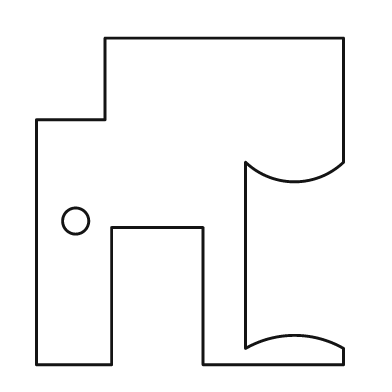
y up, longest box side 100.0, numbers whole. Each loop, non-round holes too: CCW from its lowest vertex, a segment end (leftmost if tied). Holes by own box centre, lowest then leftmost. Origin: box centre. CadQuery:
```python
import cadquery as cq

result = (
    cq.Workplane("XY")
    .moveTo(-47.0, -50.0)
    .lineTo(-24.0, -50.0)
    .lineTo(-24.0, -8.0)
    .lineTo(4.0, -8.0)
    .lineTo(4.0, -50.0)
    .lineTo(47.0, -50.0)
    .lineTo(47.0, -45.0)
    .threePointArc((32.0, -41.0), (17.0, -45.0))
    .lineTo(17.0, 12.0)
    .threePointArc((32.0, 6.0), (47.0, 12.0))
    .lineTo(47.0, 50.0)
    .lineTo(-26.0, 50.0)
    .lineTo(-26.0, 25.0)
    .lineTo(-47.0, 25.0)
    .close()
    .moveTo(-35.0, -6.0)
    .circle(4.0)
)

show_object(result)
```